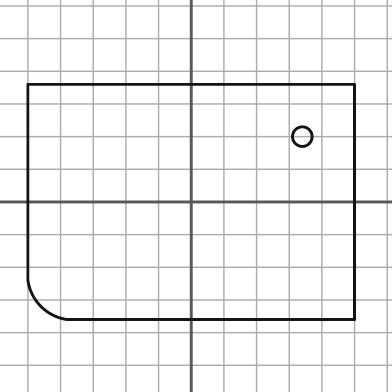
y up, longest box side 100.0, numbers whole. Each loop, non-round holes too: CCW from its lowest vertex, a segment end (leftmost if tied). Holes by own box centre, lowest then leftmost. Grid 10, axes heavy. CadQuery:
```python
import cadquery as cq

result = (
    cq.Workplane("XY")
    .moveTo(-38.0, -36.0)
    .lineTo(50.0, -36.0)
    .lineTo(50.0, 36.0)
    .lineTo(-50.0, 36.0)
    .lineTo(-50.0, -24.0)
    .threePointArc((-46.0, -32.0), (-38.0, -36.0))
    .close()
    .moveTo(34.0, 20.0)
    .circle(3.0)
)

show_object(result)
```